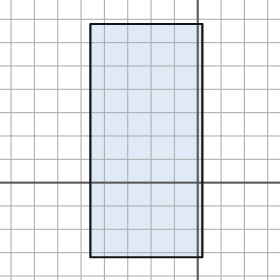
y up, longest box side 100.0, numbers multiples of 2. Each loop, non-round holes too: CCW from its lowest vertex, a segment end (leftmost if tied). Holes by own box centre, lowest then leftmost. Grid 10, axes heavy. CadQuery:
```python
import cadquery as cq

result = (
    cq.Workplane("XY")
    .moveTo(-46.0, -32.0)
    .lineTo(2.0, -32.0)
    .lineTo(2.0, 68.0)
    .lineTo(-46.0, 68.0)
    .close()
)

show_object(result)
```